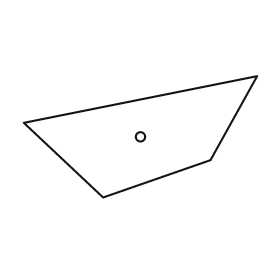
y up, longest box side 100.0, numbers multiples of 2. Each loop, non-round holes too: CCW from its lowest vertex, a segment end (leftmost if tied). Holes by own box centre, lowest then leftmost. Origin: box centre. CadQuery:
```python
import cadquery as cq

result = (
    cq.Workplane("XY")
    .moveTo(-16.0, -26.0)
    .lineTo(30.0, -10.0)
    .lineTo(50.0, 26.0)
    .lineTo(-50.0, 6.0)
    .close()
    .moveTo(0.0, 0.0)
    .circle(2.0)
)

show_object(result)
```